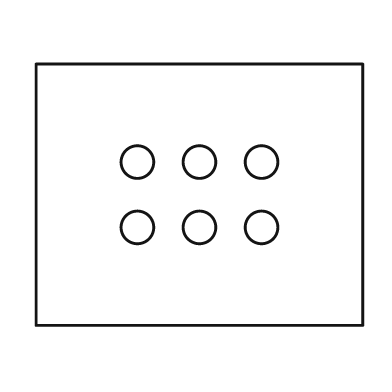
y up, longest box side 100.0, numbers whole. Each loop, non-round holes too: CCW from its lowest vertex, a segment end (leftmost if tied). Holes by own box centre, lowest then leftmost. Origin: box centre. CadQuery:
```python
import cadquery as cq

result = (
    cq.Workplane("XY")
    .moveTo(-50.0, -40.0)
    .lineTo(50.0, -40.0)
    .lineTo(50.0, 40.0)
    .lineTo(-50.0, 40.0)
    .close()
    .moveTo(-19.0, -10.0)
    .circle(5.0)
    .moveTo(0.0, -10.0)
    .circle(5.0)
    .moveTo(19.0, -10.0)
    .circle(5.0)
    .moveTo(-19.0, 10.0)
    .circle(5.0)
    .moveTo(0.0, 10.0)
    .circle(5.0)
    .moveTo(19.0, 10.0)
    .circle(5.0)
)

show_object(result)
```